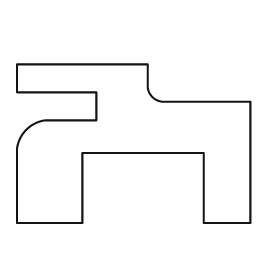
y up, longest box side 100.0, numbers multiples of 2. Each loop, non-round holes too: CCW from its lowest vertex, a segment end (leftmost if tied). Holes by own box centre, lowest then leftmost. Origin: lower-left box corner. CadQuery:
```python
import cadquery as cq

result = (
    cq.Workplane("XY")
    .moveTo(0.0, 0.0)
    .lineTo(28.0, 0.0)
    .lineTo(28.0, 30.0)
    .lineTo(80.0, 30.0)
    .lineTo(80.0, 0.0)
    .lineTo(100.0, 0.0)
    .lineTo(100.0, 52.0)
    .lineTo(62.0, 52.0)
    .threePointArc((58.0, 54.0), (56.0, 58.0))
    .lineTo(56.0, 68.0)
    .lineTo(0.0, 68.0)
    .lineTo(0.0, 56.0)
    .lineTo(34.0, 56.0)
    .lineTo(34.0, 44.0)
    .lineTo(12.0, 44.0)
    .threePointArc((4.0, 40.0), (0.0, 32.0))
    .close()
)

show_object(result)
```